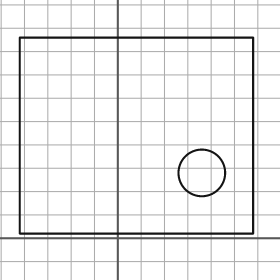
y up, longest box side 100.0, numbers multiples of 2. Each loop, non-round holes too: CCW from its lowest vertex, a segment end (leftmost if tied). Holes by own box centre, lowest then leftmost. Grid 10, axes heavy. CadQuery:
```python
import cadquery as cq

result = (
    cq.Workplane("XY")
    .moveTo(-42.0, 2.0)
    .lineTo(58.0, 2.0)
    .lineTo(58.0, 86.0)
    .lineTo(-42.0, 86.0)
    .close()
    .moveTo(36.0, 28.0)
    .circle(10.0)
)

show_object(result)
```